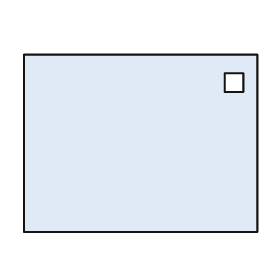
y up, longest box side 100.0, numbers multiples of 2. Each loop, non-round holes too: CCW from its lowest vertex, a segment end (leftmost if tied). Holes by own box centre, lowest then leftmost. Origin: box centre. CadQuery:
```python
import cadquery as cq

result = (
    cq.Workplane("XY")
    .moveTo(-50.0, -38.0)
    .lineTo(50.0, -38.0)
    .lineTo(50.0, 38.0)
    .lineTo(-50.0, 38.0)
    .close()
    .moveTo(36.0, 22.0)
    .lineTo(44.0, 22.0)
    .lineTo(44.0, 30.0)
    .lineTo(36.0, 30.0)
    .close()
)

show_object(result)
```